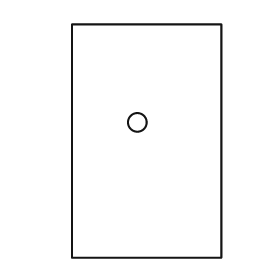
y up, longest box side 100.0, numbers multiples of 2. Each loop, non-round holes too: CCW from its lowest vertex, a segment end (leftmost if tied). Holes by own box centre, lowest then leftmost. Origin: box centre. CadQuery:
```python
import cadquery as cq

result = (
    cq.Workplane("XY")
    .moveTo(-32.0, -50.0)
    .lineTo(32.0, -50.0)
    .lineTo(32.0, 50.0)
    .lineTo(-32.0, 50.0)
    .close()
    .moveTo(-4.0, 8.0)
    .circle(4.0)
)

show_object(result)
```